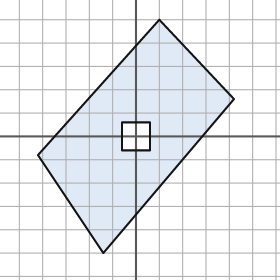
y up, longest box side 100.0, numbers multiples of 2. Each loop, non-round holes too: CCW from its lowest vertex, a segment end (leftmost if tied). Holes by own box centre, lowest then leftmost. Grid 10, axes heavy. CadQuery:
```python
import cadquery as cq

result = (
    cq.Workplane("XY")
    .moveTo(-14.0, -50.0)
    .lineTo(42.0, 16.0)
    .lineTo(10.0, 50.0)
    .lineTo(-42.0, -8.0)
    .close()
    .moveTo(-6.0, -6.0)
    .lineTo(6.0, -6.0)
    .lineTo(6.0, 6.0)
    .lineTo(-6.0, 6.0)
    .close()
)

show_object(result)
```